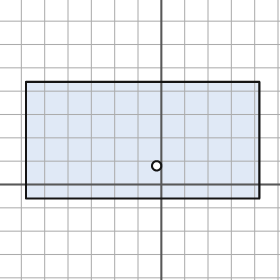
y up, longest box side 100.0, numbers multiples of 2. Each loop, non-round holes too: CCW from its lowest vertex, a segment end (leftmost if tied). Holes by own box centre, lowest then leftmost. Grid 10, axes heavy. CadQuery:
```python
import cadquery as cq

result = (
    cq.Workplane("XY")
    .moveTo(-58.0, -6.0)
    .lineTo(42.0, -6.0)
    .lineTo(42.0, 44.0)
    .lineTo(-58.0, 44.0)
    .close()
    .moveTo(-2.0, 8.0)
    .circle(2.0)
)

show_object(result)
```